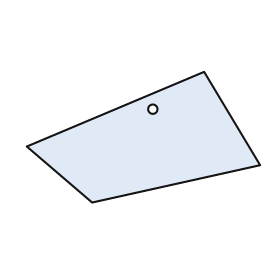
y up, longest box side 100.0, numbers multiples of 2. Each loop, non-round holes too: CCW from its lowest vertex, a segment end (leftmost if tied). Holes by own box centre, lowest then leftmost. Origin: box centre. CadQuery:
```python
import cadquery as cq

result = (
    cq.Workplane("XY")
    .moveTo(-22.0, -28.0)
    .lineTo(50.0, -12.0)
    .lineTo(26.0, 28.0)
    .lineTo(-50.0, -4.0)
    .close()
    .moveTo(4.0, 12.0)
    .circle(2.0)
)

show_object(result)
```